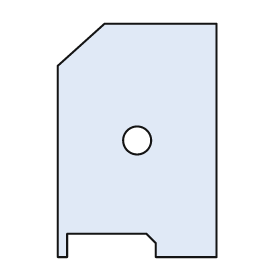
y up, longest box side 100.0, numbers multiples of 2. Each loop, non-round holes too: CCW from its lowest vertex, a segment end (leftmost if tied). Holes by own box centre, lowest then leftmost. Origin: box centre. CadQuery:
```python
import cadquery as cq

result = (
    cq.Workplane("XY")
    .moveTo(-34.0, -50.0)
    .lineTo(-30.0, -50.0)
    .lineTo(-30.0, -40.0)
    .lineTo(4.0, -40.0)
    .lineTo(8.0, -44.0)
    .lineTo(8.0, -50.0)
    .lineTo(34.0, -50.0)
    .lineTo(34.0, 50.0)
    .lineTo(-14.0, 50.0)
    .lineTo(-34.0, 32.0)
    .close()
    .moveTo(0.0, 0.0)
    .circle(6.0)
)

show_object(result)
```